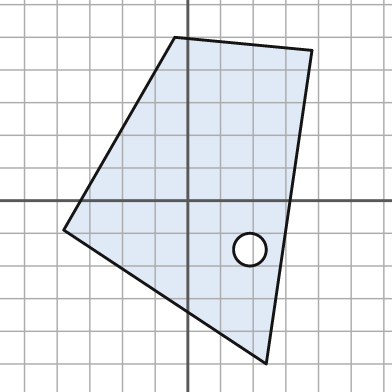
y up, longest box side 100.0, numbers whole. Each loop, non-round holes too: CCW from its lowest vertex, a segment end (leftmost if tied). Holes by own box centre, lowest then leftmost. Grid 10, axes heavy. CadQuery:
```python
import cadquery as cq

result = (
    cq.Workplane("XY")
    .moveTo(24.0, -50.0)
    .lineTo(38.0, 46.0)
    .lineTo(-4.0, 50.0)
    .lineTo(-38.0, -9.0)
    .close()
    .moveTo(19.0, -15.0)
    .circle(5.0)
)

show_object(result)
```